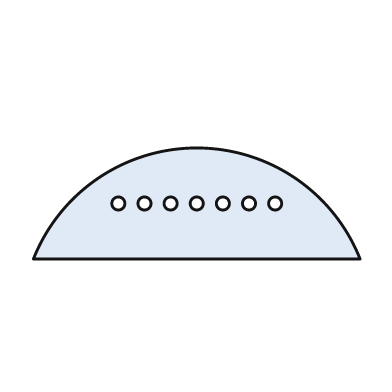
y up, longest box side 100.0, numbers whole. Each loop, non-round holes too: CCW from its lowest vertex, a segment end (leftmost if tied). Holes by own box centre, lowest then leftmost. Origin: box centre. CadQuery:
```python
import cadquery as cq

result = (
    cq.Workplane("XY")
    .moveTo(-50.0, -17.0)
    .lineTo(50.0, -17.0)
    .threePointArc((0.0, 17.0), (-50.0, -17.0))
    .close()
    .moveTo(-24.0, 0.0)
    .circle(2.0)
    .moveTo(-16.0, 0.0)
    .circle(2.0)
    .moveTo(-8.0, 0.0)
    .circle(2.0)
    .moveTo(0.0, 0.0)
    .circle(2.0)
    .moveTo(8.0, 0.0)
    .circle(2.0)
    .moveTo(16.0, 0.0)
    .circle(2.0)
    .moveTo(24.0, 0.0)
    .circle(2.0)
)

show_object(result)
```